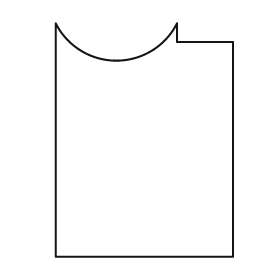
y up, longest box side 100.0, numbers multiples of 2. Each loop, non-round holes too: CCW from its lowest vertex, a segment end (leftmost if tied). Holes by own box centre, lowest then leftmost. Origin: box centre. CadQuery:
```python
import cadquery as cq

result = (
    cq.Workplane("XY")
    .moveTo(-38.0, -50.0)
    .lineTo(38.0, -50.0)
    .lineTo(38.0, 42.0)
    .lineTo(14.0, 42.0)
    .lineTo(14.0, 50.0)
    .threePointArc((-12.0, 34.0), (-38.0, 50.0))
    .close()
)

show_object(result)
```